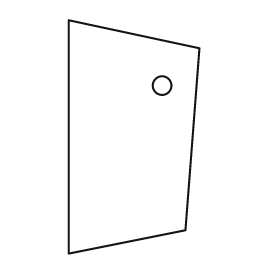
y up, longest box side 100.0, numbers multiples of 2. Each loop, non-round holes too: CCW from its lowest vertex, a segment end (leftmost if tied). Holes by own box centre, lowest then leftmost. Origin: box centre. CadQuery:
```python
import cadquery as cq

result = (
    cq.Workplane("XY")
    .moveTo(-28.0, -50.0)
    .lineTo(22.0, -40.0)
    .lineTo(28.0, 38.0)
    .lineTo(-28.0, 50.0)
    .close()
    .moveTo(12.0, 22.0)
    .circle(4.0)
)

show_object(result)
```